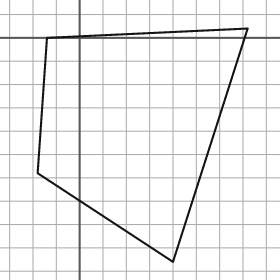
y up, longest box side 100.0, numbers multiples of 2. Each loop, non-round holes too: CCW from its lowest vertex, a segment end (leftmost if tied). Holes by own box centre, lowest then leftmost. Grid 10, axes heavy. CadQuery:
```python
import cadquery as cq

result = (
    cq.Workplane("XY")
    .moveTo(40.0, -96.0)
    .lineTo(72.0, 4.0)
    .lineTo(-14.0, 0.0)
    .lineTo(-18.0, -58.0)
    .close()
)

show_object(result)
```